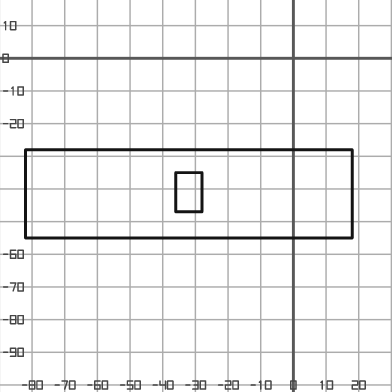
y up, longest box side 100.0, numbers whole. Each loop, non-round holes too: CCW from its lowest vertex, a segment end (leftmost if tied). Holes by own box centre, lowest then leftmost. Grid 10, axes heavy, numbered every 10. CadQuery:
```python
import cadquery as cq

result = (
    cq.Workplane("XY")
    .moveTo(-82.0, -55.0)
    .lineTo(18.0, -55.0)
    .lineTo(18.0, -28.0)
    .lineTo(-82.0, -28.0)
    .close()
    .moveTo(-36.0, -47.0)
    .lineTo(-28.0, -47.0)
    .lineTo(-28.0, -35.0)
    .lineTo(-36.0, -35.0)
    .close()
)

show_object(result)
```